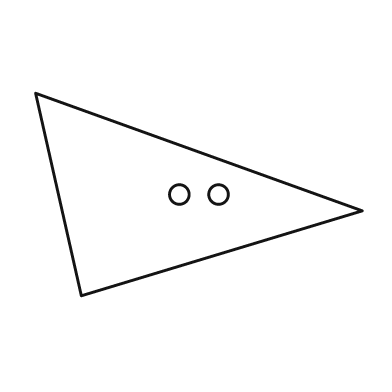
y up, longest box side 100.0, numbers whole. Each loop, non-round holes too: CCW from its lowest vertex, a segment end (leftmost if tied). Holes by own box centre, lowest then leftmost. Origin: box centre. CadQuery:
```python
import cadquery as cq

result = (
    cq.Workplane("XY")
    .moveTo(-36.0, -31.0)
    .lineTo(50.0, -5.0)
    .lineTo(-50.0, 31.0)
    .close()
    .moveTo(-6.0, 0.0)
    .circle(3.0)
    .moveTo(6.0, 0.0)
    .circle(3.0)
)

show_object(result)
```